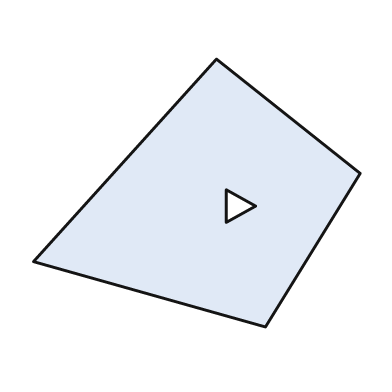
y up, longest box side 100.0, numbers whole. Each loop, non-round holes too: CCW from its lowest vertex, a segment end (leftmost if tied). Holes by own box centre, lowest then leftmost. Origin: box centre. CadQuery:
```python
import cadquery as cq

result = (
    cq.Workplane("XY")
    .moveTo(21.0, -41.0)
    .lineTo(50.0, 6.0)
    .lineTo(6.0, 41.0)
    .lineTo(-50.0, -21.0)
    .close()
    .moveTo(9.0, -9.0)
    .lineTo(18.0, -4.0)
    .lineTo(9.0, 1.0)
    .close()
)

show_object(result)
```